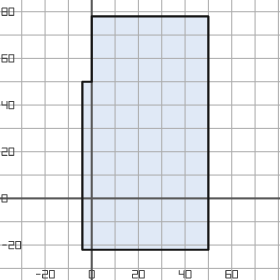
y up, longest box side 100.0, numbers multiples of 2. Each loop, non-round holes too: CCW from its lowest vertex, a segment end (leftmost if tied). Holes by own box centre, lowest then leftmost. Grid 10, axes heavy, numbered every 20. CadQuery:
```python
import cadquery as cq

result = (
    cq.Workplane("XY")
    .moveTo(-4.0, -22.0)
    .lineTo(50.0, -22.0)
    .lineTo(50.0, 78.0)
    .lineTo(0.0, 78.0)
    .lineTo(0.0, 50.0)
    .lineTo(-4.0, 50.0)
    .close()
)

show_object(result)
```